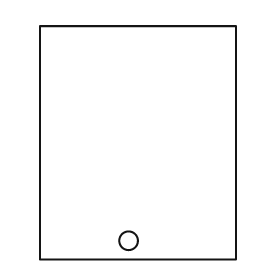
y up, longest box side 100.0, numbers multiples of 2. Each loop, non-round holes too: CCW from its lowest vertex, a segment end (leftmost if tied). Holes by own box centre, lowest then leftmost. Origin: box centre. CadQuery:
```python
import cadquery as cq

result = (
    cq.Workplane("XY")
    .moveTo(-42.0, -50.0)
    .lineTo(42.0, -50.0)
    .lineTo(42.0, 50.0)
    .lineTo(-42.0, 50.0)
    .close()
    .moveTo(-4.0, -42.0)
    .circle(4.0)
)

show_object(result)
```